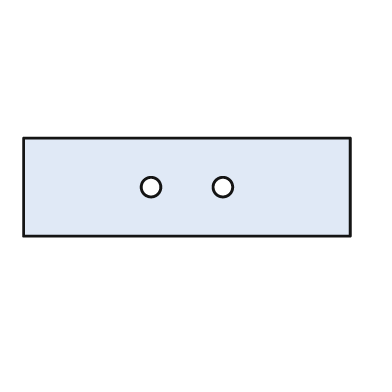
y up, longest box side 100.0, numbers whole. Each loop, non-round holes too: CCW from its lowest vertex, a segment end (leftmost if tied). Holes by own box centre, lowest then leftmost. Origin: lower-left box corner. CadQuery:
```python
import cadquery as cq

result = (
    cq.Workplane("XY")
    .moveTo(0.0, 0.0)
    .lineTo(100.0, 0.0)
    .lineTo(100.0, 30.0)
    .lineTo(0.0, 30.0)
    .close()
    .moveTo(39.0, 15.0)
    .circle(3.0)
    .moveTo(61.0, 15.0)
    .circle(3.0)
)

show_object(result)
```